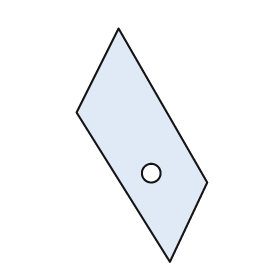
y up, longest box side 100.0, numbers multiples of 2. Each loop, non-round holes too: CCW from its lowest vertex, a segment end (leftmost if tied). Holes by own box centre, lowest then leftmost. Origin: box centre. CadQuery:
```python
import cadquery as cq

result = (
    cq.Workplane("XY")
    .moveTo(12.0, -50.0)
    .lineTo(28.0, -16.0)
    .lineTo(-10.0, 50.0)
    .lineTo(-28.0, 14.0)
    .close()
    .moveTo(4.0, -12.0)
    .circle(4.0)
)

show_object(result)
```